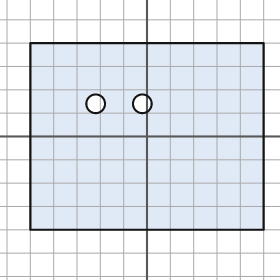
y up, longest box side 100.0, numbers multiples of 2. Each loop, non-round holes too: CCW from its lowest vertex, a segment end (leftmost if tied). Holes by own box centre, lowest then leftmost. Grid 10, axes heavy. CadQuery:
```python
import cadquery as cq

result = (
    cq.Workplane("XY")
    .moveTo(-50.0, -40.0)
    .lineTo(50.0, -40.0)
    .lineTo(50.0, 40.0)
    .lineTo(-50.0, 40.0)
    .close()
    .moveTo(-22.0, 14.0)
    .circle(4.0)
    .moveTo(-2.0, 14.0)
    .circle(4.0)
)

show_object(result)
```